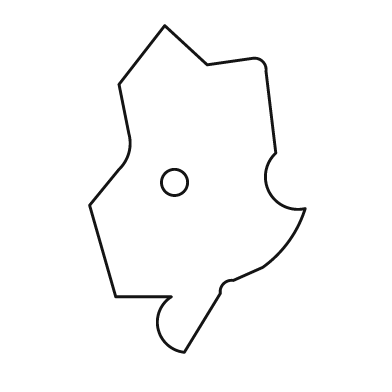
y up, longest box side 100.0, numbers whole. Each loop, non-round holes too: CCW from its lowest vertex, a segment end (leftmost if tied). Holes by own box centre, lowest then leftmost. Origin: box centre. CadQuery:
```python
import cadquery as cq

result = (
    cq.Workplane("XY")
    .moveTo(-4.0, -50.0)
    .lineTo(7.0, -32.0)
    .threePointArc((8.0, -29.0), (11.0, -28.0))
    .lineTo(20.0, -24.0)
    .threePointArc((28.0, -16.0), (33.0, -6.0))
    .threePointArc((22.0, -1.0), (24.0, 11.0))
    .lineTo(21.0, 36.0)
    .threePointArc((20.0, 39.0), (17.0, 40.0))
    .lineTo(3.0, 38.0)
    .lineTo(-10.0, 50.0)
    .lineTo(-24.0, 32.0)
    .lineTo(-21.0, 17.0)
    .threePointArc((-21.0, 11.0), (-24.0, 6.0))
    .lineTo(-33.0, -5.0)
    .lineTo(-25.0, -33.0)
    .lineTo(-8.0, -33.0)
    .threePointArc((-12.0, -43.0), (-4.0, -50.0))
    .close()
    .moveTo(-7.0, 2.0)
    .circle(4.0)
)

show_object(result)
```